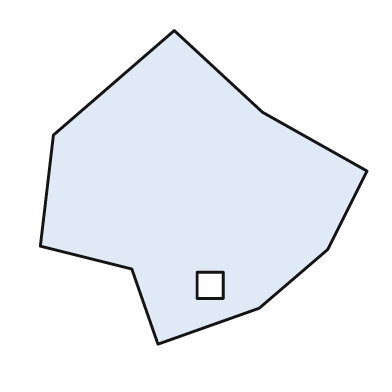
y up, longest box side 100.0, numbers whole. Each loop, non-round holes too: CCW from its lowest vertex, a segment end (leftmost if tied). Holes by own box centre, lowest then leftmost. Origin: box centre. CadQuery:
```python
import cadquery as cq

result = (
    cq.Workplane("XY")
    .moveTo(-14.0, -48.0)
    .lineTo(17.0, -37.0)
    .lineTo(38.0, -19.0)
    .lineTo(50.0, 5.0)
    .lineTo(18.0, 23.0)
    .lineTo(-9.0, 48.0)
    .lineTo(-46.0, 16.0)
    .lineTo(-50.0, -18.0)
    .lineTo(-22.0, -25.0)
    .close()
    .moveTo(-2.0, -34.0)
    .lineTo(6.0, -34.0)
    .lineTo(6.0, -26.0)
    .lineTo(-2.0, -26.0)
    .close()
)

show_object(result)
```